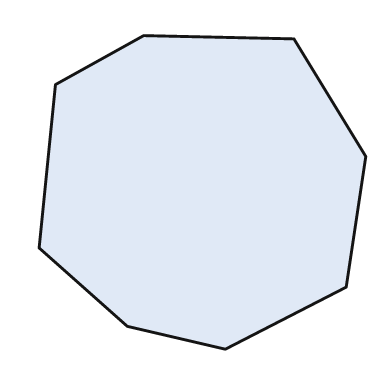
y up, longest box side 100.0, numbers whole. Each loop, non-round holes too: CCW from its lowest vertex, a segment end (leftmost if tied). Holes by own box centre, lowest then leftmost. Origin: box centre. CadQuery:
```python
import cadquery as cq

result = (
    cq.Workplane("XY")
    .moveTo(7.0, -48.0)
    .lineTo(44.0, -29.0)
    .lineTo(50.0, 11.0)
    .lineTo(28.0, 47.0)
    .lineTo(-18.0, 48.0)
    .lineTo(-45.0, 33.0)
    .lineTo(-50.0, -17.0)
    .lineTo(-23.0, -41.0)
    .close()
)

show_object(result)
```